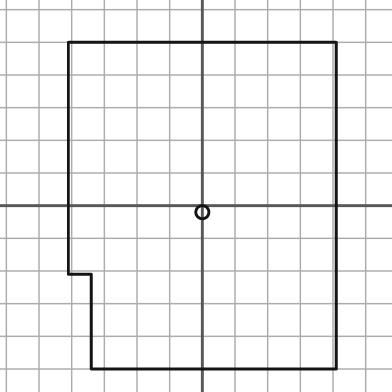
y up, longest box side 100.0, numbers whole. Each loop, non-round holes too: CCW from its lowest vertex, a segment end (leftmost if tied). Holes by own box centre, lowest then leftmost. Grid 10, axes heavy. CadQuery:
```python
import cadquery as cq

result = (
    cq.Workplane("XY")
    .moveTo(-34.0, -50.0)
    .lineTo(41.0, -50.0)
    .lineTo(41.0, 50.0)
    .lineTo(-41.0, 50.0)
    .lineTo(-41.0, -21.0)
    .lineTo(-34.0, -21.0)
    .close()
    .moveTo(0.0, -2.0)
    .circle(2.0)
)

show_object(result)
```